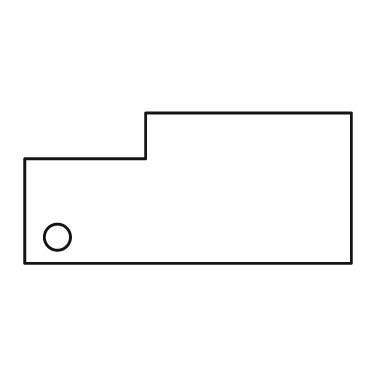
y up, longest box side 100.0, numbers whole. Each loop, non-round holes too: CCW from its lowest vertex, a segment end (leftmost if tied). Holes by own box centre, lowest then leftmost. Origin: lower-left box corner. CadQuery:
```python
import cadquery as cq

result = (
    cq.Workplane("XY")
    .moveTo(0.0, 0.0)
    .lineTo(100.0, 0.0)
    .lineTo(100.0, 46.0)
    .lineTo(37.0, 46.0)
    .lineTo(37.0, 32.0)
    .lineTo(0.0, 32.0)
    .close()
    .moveTo(10.0, 8.0)
    .circle(4.0)
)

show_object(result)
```